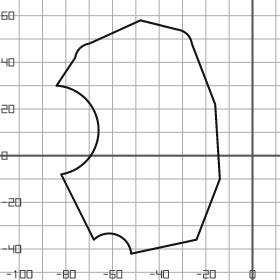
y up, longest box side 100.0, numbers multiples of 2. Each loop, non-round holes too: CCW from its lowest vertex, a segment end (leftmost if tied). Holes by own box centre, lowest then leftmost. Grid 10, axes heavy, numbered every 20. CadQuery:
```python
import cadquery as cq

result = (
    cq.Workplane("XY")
    .moveTo(-52.0, -42.0)
    .lineTo(-24.0, -36.0)
    .lineTo(-14.0, -10.0)
    .lineTo(-16.0, 22.0)
    .lineTo(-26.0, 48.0)
    .threePointArc((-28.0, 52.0), (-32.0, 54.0))
    .lineTo(-48.0, 58.0)
    .lineTo(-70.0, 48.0)
    .threePointArc((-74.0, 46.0), (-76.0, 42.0))
    .lineTo(-84.0, 30.0)
    .threePointArc((-66.0, 12.0), (-82.0, -8.0))
    .lineTo(-68.0, -36.0)
    .threePointArc((-58.0, -34.0), (-52.0, -42.0))
    .close()
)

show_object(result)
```